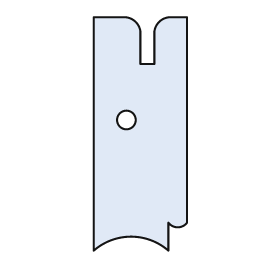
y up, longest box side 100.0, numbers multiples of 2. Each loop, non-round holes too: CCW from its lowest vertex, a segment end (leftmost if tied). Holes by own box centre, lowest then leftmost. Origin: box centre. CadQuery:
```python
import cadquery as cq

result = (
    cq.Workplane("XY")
    .moveTo(-20.0, -50.0)
    .threePointArc((-4.0, -44.0), (12.0, -50.0))
    .lineTo(12.0, -38.0)
    .threePointArc((16.0, -40.0), (20.0, -38.0))
    .lineTo(20.0, 50.0)
    .lineTo(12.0, 50.0)
    .threePointArc((8.0, 48.0), (6.0, 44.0))
    .lineTo(6.0, 30.0)
    .lineTo(0.0, 30.0)
    .lineTo(0.0, 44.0)
    .threePointArc((-2.0, 48.0), (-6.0, 50.0))
    .lineTo(-20.0, 50.0)
    .close()
    .moveTo(-6.0, 6.0)
    .circle(4.0)
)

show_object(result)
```